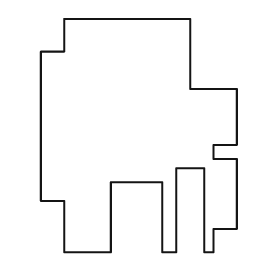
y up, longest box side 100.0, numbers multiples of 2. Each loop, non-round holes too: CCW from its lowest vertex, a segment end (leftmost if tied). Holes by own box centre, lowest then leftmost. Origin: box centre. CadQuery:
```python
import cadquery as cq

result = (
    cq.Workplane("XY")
    .moveTo(-32.0, -50.0)
    .lineTo(-12.0, -50.0)
    .lineTo(-12.0, -20.0)
    .lineTo(10.0, -20.0)
    .lineTo(10.0, -50.0)
    .lineTo(16.0, -50.0)
    .lineTo(16.0, -14.0)
    .lineTo(28.0, -14.0)
    .lineTo(28.0, -50.0)
    .lineTo(32.0, -50.0)
    .lineTo(32.0, -40.0)
    .lineTo(42.0, -40.0)
    .lineTo(42.0, -10.0)
    .lineTo(32.0, -10.0)
    .lineTo(32.0, -4.0)
    .lineTo(42.0, -4.0)
    .lineTo(42.0, 20.0)
    .lineTo(22.0, 20.0)
    .lineTo(22.0, 50.0)
    .lineTo(-32.0, 50.0)
    .lineTo(-32.0, 36.0)
    .lineTo(-42.0, 36.0)
    .lineTo(-42.0, -28.0)
    .lineTo(-32.0, -28.0)
    .close()
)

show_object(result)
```